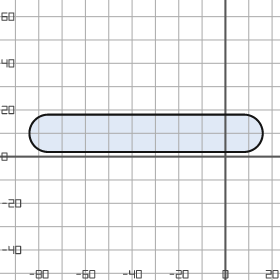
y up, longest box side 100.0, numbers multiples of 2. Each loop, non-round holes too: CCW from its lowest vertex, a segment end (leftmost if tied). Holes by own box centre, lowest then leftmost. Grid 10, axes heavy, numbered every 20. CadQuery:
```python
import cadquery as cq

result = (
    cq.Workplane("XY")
    .moveTo(-76.0, 2.0)
    .lineTo(8.0, 2.0)
    .threePointArc((16.0, 10.0), (8.0, 18.0))
    .lineTo(-76.0, 18.0)
    .threePointArc((-84.0, 10.0), (-76.0, 2.0))
    .close()
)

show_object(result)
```